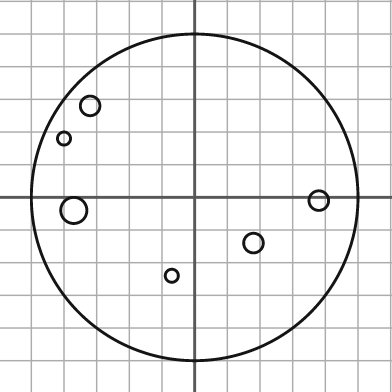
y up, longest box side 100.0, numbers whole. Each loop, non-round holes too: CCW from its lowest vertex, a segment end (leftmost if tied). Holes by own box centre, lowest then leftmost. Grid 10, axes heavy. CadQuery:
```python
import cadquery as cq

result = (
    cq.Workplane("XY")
    .moveTo(0.0, 0.0)
    .circle(50.0)
    .moveTo(-7.0, -24.0)
    .circle(2.0)
    .moveTo(18.0, -14.0)
    .circle(3.0)
    .moveTo(-37.0, -4.0)
    .circle(4.0)
    .moveTo(38.0, -1.0)
    .circle(3.0)
    .moveTo(-40.0, 18.0)
    .circle(2.0)
    .moveTo(-32.0, 28.0)
    .circle(3.0)
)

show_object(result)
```